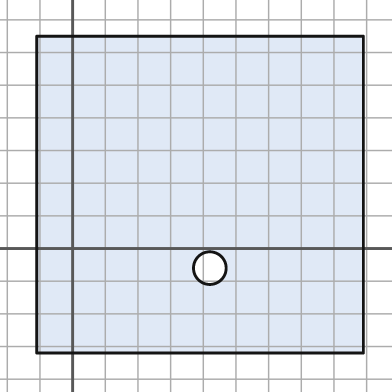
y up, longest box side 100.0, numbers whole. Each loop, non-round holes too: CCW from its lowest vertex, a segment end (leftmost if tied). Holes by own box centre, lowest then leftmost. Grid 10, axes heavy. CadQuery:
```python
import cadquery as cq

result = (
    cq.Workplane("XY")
    .moveTo(-11.0, -32.0)
    .lineTo(89.0, -32.0)
    .lineTo(89.0, 65.0)
    .lineTo(-11.0, 65.0)
    .close()
    .moveTo(42.0, -6.0)
    .circle(5.0)
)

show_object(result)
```